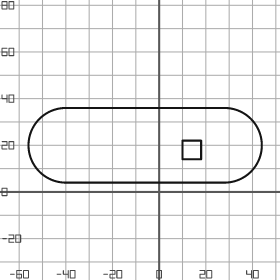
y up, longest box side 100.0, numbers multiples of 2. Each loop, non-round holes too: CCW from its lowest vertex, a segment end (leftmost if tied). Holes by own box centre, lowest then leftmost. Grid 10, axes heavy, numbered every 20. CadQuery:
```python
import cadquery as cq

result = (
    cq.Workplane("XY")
    .moveTo(-40.0, 4.0)
    .lineTo(28.0, 4.0)
    .threePointArc((44.0, 20.0), (28.0, 36.0))
    .lineTo(-40.0, 36.0)
    .threePointArc((-56.0, 20.0), (-40.0, 4.0))
    .close()
    .moveTo(10.0, 14.0)
    .lineTo(18.0, 14.0)
    .lineTo(18.0, 22.0)
    .lineTo(10.0, 22.0)
    .close()
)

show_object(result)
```